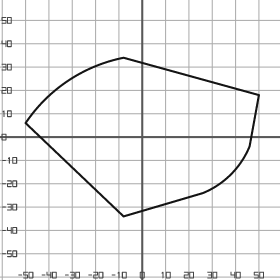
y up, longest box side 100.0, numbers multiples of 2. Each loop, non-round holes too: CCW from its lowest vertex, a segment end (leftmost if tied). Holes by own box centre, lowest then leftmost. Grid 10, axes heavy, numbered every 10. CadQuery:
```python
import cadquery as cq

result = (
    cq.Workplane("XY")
    .moveTo(-8.0, -34.0)
    .lineTo(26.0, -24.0)
    .threePointArc((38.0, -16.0), (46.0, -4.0))
    .lineTo(50.0, 18.0)
    .lineTo(-8.0, 34.0)
    .threePointArc((-32.0, 24.0), (-50.0, 6.0))
    .close()
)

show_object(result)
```